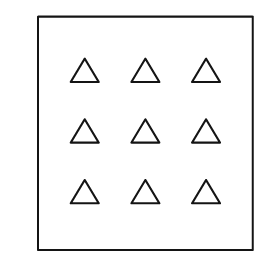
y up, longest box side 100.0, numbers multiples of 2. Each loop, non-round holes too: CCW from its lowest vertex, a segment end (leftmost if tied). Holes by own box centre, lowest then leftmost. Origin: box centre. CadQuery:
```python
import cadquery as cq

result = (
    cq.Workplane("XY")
    .moveTo(-46.0, -50.0)
    .lineTo(46.0, -50.0)
    .lineTo(46.0, 50.0)
    .lineTo(-46.0, 50.0)
    .close()
    .moveTo(-32.0, -30.0)
    .lineTo(-20.0, -30.0)
    .lineTo(-26.0, -20.0)
    .close()
    .moveTo(-6.0, -30.0)
    .lineTo(6.0, -30.0)
    .lineTo(0.0, -20.0)
    .close()
    .moveTo(20.0, -30.0)
    .lineTo(32.0, -30.0)
    .lineTo(26.0, -20.0)
    .close()
    .moveTo(-32.0, -4.0)
    .lineTo(-20.0, -4.0)
    .lineTo(-26.0, 6.0)
    .close()
    .moveTo(-6.0, -4.0)
    .lineTo(6.0, -4.0)
    .lineTo(0.0, 6.0)
    .close()
    .moveTo(20.0, -4.0)
    .lineTo(32.0, -4.0)
    .lineTo(26.0, 6.0)
    .close()
    .moveTo(-32.0, 22.0)
    .lineTo(-20.0, 22.0)
    .lineTo(-26.0, 32.0)
    .close()
    .moveTo(-6.0, 22.0)
    .lineTo(6.0, 22.0)
    .lineTo(0.0, 32.0)
    .close()
    .moveTo(20.0, 22.0)
    .lineTo(32.0, 22.0)
    .lineTo(26.0, 32.0)
    .close()
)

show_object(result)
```